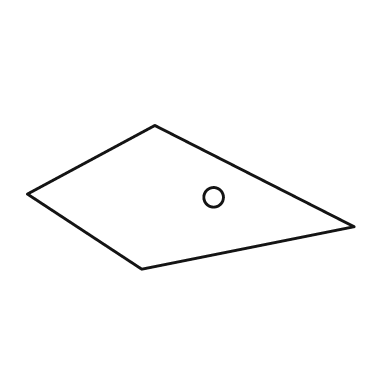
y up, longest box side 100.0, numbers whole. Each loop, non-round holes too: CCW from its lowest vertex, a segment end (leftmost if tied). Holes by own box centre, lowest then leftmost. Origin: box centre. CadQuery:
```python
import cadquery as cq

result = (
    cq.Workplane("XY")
    .moveTo(-15.0, -22.0)
    .lineTo(50.0, -9.0)
    .lineTo(-11.0, 22.0)
    .lineTo(-50.0, 1.0)
    .close()
    .moveTo(7.0, 0.0)
    .circle(3.0)
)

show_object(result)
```